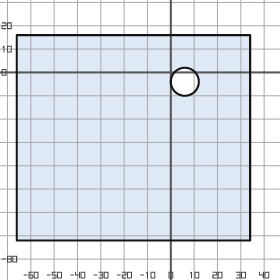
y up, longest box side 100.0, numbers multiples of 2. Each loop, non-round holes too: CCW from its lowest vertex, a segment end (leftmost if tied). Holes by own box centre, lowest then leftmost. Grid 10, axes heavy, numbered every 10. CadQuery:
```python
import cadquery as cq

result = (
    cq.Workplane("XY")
    .moveTo(-66.0, -72.0)
    .lineTo(34.0, -72.0)
    .lineTo(34.0, 16.0)
    .lineTo(-66.0, 16.0)
    .close()
    .moveTo(6.0, -4.0)
    .circle(6.0)
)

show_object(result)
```